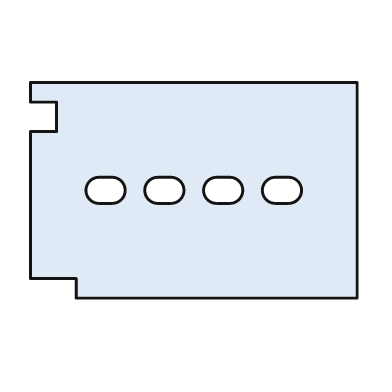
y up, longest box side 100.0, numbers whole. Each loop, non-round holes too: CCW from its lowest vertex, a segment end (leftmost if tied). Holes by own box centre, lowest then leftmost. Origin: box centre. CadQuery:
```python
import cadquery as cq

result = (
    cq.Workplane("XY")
    .moveTo(-36.0, -33.0)
    .lineTo(50.0, -33.0)
    .lineTo(50.0, 33.0)
    .lineTo(-50.0, 33.0)
    .lineTo(-50.0, 27.0)
    .lineTo(-42.0, 27.0)
    .lineTo(-42.0, 18.0)
    .lineTo(-50.0, 18.0)
    .lineTo(-50.0, -27.0)
    .lineTo(-36.0, -27.0)
    .close()
    .moveTo(-29.0, -4.0)
    .lineTo(-25.0, -4.0)
    .threePointArc((-21.0, 0.0), (-25.0, 4.0))
    .lineTo(-29.0, 4.0)
    .threePointArc((-33.0, 0.0), (-29.0, -4.0))
    .close()
    .moveTo(-11.0, -4.0)
    .lineTo(-7.0, -4.0)
    .threePointArc((-3.0, 0.0), (-7.0, 4.0))
    .lineTo(-11.0, 4.0)
    .threePointArc((-15.0, 0.0), (-11.0, -4.0))
    .close()
    .moveTo(7.0, -4.0)
    .lineTo(11.0, -4.0)
    .threePointArc((15.0, 0.0), (11.0, 4.0))
    .lineTo(7.0, 4.0)
    .threePointArc((3.0, 0.0), (7.0, -4.0))
    .close()
    .moveTo(25.0, -4.0)
    .lineTo(29.0, -4.0)
    .threePointArc((33.0, 0.0), (29.0, 4.0))
    .lineTo(25.0, 4.0)
    .threePointArc((21.0, 0.0), (25.0, -4.0))
    .close()
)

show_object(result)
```